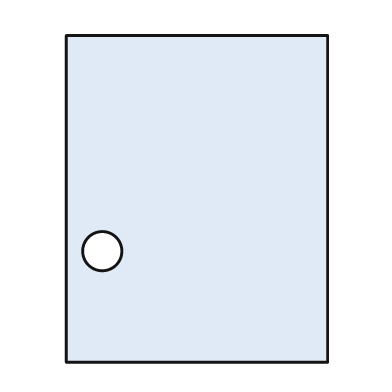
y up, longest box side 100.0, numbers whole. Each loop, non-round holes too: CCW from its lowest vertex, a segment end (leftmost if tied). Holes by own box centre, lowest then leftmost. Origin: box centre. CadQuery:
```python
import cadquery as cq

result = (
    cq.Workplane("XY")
    .moveTo(-40.0, -50.0)
    .lineTo(40.0, -50.0)
    .lineTo(40.0, 50.0)
    .lineTo(-40.0, 50.0)
    .close()
    .moveTo(-29.0, -16.0)
    .circle(6.0)
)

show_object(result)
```